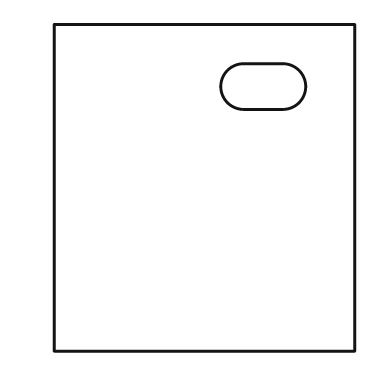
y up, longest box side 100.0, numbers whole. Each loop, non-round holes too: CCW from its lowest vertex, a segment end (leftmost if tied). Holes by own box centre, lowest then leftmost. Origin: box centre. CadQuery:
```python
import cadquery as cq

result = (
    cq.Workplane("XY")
    .moveTo(-46.0, -50.0)
    .lineTo(46.0, -50.0)
    .lineTo(46.0, 50.0)
    .lineTo(-46.0, 50.0)
    .close()
    .moveTo(12.0, 24.0)
    .lineTo(24.0, 24.0)
    .threePointArc((31.0, 31.0), (24.0, 38.0))
    .lineTo(12.0, 38.0)
    .threePointArc((5.0, 31.0), (12.0, 24.0))
    .close()
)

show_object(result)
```